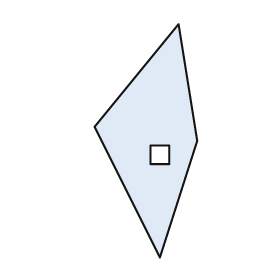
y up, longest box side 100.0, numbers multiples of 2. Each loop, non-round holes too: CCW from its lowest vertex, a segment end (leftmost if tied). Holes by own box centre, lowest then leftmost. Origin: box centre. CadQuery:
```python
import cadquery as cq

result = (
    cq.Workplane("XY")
    .moveTo(6.0, -50.0)
    .lineTo(22.0, 0.0)
    .lineTo(14.0, 50.0)
    .lineTo(-22.0, 6.0)
    .close()
    .moveTo(2.0, -10.0)
    .lineTo(10.0, -10.0)
    .lineTo(10.0, -2.0)
    .lineTo(2.0, -2.0)
    .close()
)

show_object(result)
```